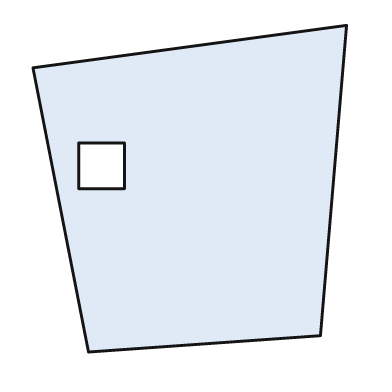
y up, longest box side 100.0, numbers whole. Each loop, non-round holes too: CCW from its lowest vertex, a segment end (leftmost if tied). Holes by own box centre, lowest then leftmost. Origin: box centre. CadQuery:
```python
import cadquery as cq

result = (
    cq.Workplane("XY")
    .moveTo(-31.0, -50.0)
    .lineTo(40.0, -45.0)
    .lineTo(48.0, 50.0)
    .lineTo(-48.0, 37.0)
    .close()
    .moveTo(-34.0, 0.0)
    .lineTo(-20.0, 0.0)
    .lineTo(-20.0, 14.0)
    .lineTo(-34.0, 14.0)
    .close()
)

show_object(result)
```